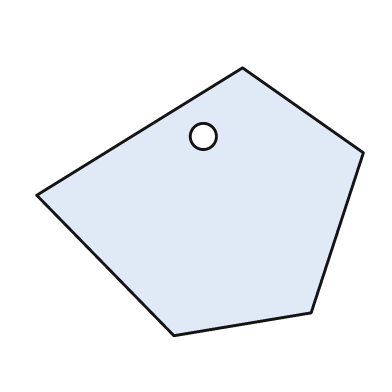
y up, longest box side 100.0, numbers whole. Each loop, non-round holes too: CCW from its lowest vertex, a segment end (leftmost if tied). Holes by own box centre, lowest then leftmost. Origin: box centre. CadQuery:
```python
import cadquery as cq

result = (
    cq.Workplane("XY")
    .moveTo(-8.0, -41.0)
    .lineTo(34.0, -34.0)
    .lineTo(50.0, 15.0)
    .lineTo(13.0, 41.0)
    .lineTo(-50.0, 2.0)
    .close()
    .moveTo(1.0, 20.0)
    .circle(4.0)
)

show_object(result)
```